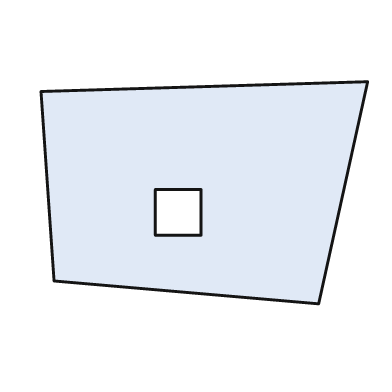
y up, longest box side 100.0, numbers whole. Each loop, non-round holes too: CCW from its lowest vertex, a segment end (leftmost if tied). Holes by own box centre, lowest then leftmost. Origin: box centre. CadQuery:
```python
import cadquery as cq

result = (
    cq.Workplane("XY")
    .moveTo(35.0, -34.0)
    .lineTo(50.0, 34.0)
    .lineTo(-50.0, 31.0)
    .lineTo(-46.0, -27.0)
    .close()
    .moveTo(-15.0, -13.0)
    .lineTo(-1.0, -13.0)
    .lineTo(-1.0, 1.0)
    .lineTo(-15.0, 1.0)
    .close()
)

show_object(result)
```